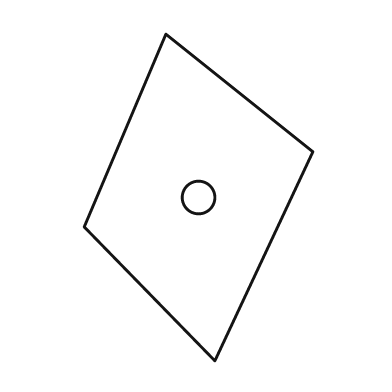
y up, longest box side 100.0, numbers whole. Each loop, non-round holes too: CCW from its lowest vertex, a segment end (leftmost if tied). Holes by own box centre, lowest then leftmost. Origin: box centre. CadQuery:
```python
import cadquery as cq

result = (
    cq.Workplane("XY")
    .moveTo(5.0, -50.0)
    .lineTo(35.0, 14.0)
    .lineTo(-10.0, 50.0)
    .lineTo(-35.0, -9.0)
    .close()
    .moveTo(0.0, 0.0)
    .circle(5.0)
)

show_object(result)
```